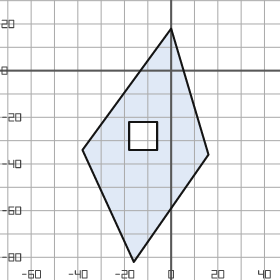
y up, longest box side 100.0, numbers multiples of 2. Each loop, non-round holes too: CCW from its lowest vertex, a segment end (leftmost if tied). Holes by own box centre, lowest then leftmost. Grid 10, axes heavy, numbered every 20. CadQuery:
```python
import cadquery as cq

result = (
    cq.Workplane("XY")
    .moveTo(-16.0, -82.0)
    .lineTo(16.0, -36.0)
    .lineTo(0.0, 18.0)
    .lineTo(-38.0, -34.0)
    .close()
    .moveTo(-18.0, -34.0)
    .lineTo(-6.0, -34.0)
    .lineTo(-6.0, -22.0)
    .lineTo(-18.0, -22.0)
    .close()
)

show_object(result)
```